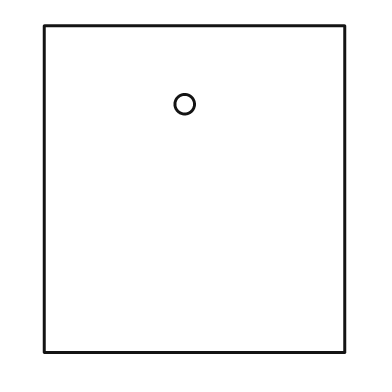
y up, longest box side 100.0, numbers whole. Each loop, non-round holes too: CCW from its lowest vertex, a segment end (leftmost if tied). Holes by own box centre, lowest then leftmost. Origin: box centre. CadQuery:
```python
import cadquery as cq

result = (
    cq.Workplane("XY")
    .moveTo(-46.0, -50.0)
    .lineTo(46.0, -50.0)
    .lineTo(46.0, 50.0)
    .lineTo(-46.0, 50.0)
    .close()
    .moveTo(-3.0, 26.0)
    .circle(3.0)
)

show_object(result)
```